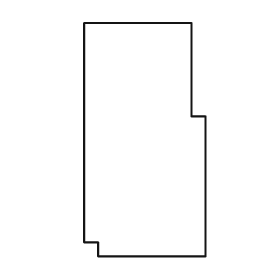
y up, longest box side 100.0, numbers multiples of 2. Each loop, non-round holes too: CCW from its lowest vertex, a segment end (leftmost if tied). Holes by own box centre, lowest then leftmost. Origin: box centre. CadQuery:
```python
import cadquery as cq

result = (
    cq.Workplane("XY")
    .moveTo(-20.0, -50.0)
    .lineTo(26.0, -50.0)
    .lineTo(26.0, 10.0)
    .lineTo(20.0, 10.0)
    .lineTo(20.0, 50.0)
    .lineTo(-26.0, 50.0)
    .lineTo(-26.0, -44.0)
    .lineTo(-20.0, -44.0)
    .close()
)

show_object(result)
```